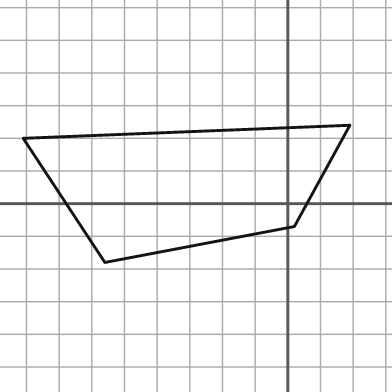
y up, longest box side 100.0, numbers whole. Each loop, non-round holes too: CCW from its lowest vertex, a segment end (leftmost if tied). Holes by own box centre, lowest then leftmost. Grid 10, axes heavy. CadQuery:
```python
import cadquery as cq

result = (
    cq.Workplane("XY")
    .moveTo(-56.0, -18.0)
    .lineTo(2.0, -7.0)
    .lineTo(19.0, 24.0)
    .lineTo(-81.0, 20.0)
    .close()
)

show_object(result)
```